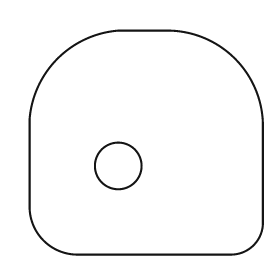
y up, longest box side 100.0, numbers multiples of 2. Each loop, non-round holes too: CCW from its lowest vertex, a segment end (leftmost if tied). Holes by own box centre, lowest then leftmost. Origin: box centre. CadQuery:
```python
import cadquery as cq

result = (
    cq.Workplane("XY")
    .moveTo(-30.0, -48.0)
    .lineTo(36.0, -48.0)
    .threePointArc((46.0, -44.0), (50.0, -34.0))
    .lineTo(50.0, 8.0)
    .threePointArc((38.0, 36.0), (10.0, 48.0))
    .lineTo(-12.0, 48.0)
    .threePointArc((-38.0, 36.0), (-50.0, 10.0))
    .lineTo(-50.0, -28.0)
    .threePointArc((-44.0, -42.0), (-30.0, -48.0))
    .close()
    .moveTo(-12.0, -10.0)
    .circle(10.0)
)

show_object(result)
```